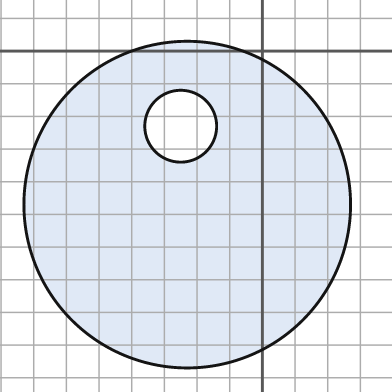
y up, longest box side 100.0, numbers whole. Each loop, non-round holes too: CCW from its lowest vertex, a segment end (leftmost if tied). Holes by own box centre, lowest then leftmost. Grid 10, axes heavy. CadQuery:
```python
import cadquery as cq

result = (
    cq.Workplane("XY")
    .moveTo(-23.0, -47.0)
    .circle(50.0)
    .moveTo(-25.0, -23.0)
    .circle(11.0)
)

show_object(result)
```